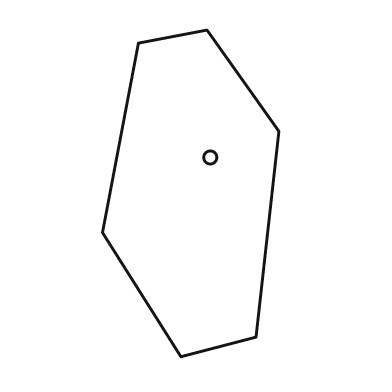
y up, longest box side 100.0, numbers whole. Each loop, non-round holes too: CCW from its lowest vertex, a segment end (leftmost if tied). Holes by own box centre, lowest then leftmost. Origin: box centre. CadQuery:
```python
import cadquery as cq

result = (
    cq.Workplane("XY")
    .moveTo(-3.0, -50.0)
    .lineTo(20.0, -44.0)
    .lineTo(27.0, 19.0)
    .lineTo(5.0, 50.0)
    .lineTo(-16.0, 46.0)
    .lineTo(-27.0, -12.0)
    .close()
    .moveTo(6.0, 11.0)
    .circle(2.0)
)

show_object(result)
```